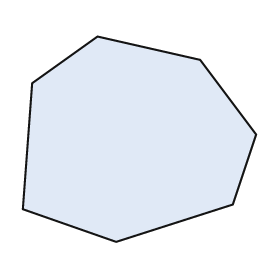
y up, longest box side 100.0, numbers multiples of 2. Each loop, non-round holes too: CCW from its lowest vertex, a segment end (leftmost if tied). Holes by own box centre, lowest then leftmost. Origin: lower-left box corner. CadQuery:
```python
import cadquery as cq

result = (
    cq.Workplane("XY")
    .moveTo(40.0, 0.0)
    .lineTo(90.0, 16.0)
    .lineTo(100.0, 46.0)
    .lineTo(76.0, 78.0)
    .lineTo(32.0, 88.0)
    .lineTo(4.0, 68.0)
    .lineTo(0.0, 14.0)
    .close()
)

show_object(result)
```